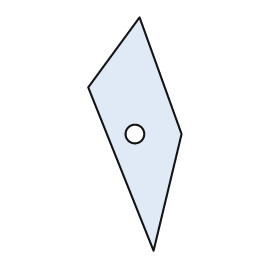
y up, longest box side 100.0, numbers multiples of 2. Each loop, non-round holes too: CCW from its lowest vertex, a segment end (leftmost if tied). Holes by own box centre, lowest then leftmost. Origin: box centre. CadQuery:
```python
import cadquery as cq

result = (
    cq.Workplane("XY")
    .moveTo(8.0, -50.0)
    .lineTo(20.0, 0.0)
    .lineTo(2.0, 50.0)
    .lineTo(-20.0, 20.0)
    .close()
    .moveTo(0.0, 0.0)
    .circle(4.0)
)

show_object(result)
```